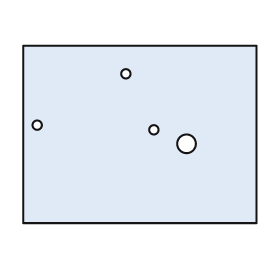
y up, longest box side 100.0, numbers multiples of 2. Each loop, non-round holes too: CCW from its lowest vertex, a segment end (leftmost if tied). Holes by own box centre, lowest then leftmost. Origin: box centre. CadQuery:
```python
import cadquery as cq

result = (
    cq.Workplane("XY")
    .moveTo(-50.0, -38.0)
    .lineTo(50.0, -38.0)
    .lineTo(50.0, 38.0)
    .lineTo(-50.0, 38.0)
    .close()
    .moveTo(20.0, -4.0)
    .circle(4.0)
    .moveTo(6.0, 2.0)
    .circle(2.0)
    .moveTo(-44.0, 4.0)
    .circle(2.0)
    .moveTo(-6.0, 26.0)
    .circle(2.0)
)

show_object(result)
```